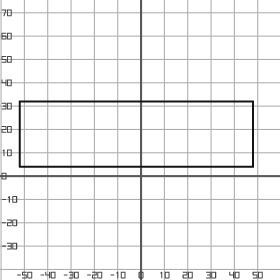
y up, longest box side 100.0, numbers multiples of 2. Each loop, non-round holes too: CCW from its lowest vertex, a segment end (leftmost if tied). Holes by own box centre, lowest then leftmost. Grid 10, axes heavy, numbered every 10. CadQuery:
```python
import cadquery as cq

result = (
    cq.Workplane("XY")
    .moveTo(-52.0, 4.0)
    .lineTo(48.0, 4.0)
    .lineTo(48.0, 32.0)
    .lineTo(-52.0, 32.0)
    .close()
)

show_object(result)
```